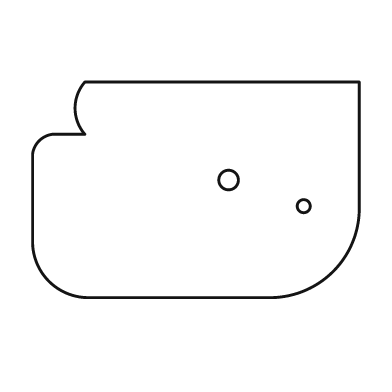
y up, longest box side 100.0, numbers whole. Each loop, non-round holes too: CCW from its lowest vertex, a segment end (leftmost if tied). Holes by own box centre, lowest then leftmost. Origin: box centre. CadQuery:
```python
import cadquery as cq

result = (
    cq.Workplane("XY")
    .moveTo(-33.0, -33.0)
    .lineTo(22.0, -33.0)
    .threePointArc((42.0, -25.0), (50.0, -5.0))
    .lineTo(50.0, 33.0)
    .lineTo(-34.0, 33.0)
    .threePointArc((-37.0, 25.0), (-34.0, 17.0))
    .lineTo(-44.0, 17.0)
    .threePointArc((-48.0, 15.0), (-50.0, 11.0))
    .lineTo(-50.0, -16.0)
    .threePointArc((-45.0, -28.0), (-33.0, -33.0))
    .close()
    .moveTo(33.0, -5.0)
    .circle(2.0)
    .moveTo(10.0, 3.0)
    .circle(3.0)
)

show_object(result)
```